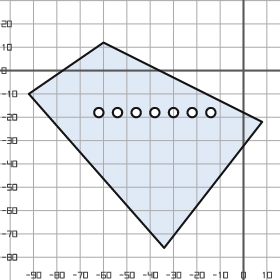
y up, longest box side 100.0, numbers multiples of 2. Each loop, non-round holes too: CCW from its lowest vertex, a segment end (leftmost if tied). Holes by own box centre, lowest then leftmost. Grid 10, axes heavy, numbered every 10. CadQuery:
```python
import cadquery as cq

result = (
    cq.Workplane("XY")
    .moveTo(-34.0, -76.0)
    .lineTo(8.0, -22.0)
    .lineTo(-60.0, 12.0)
    .lineTo(-92.0, -10.0)
    .close()
    .moveTo(-62.0, -18.0)
    .circle(2.0)
    .moveTo(-54.0, -18.0)
    .circle(2.0)
    .moveTo(-46.0, -18.0)
    .circle(2.0)
    .moveTo(-38.0, -18.0)
    .circle(2.0)
    .moveTo(-30.0, -18.0)
    .circle(2.0)
    .moveTo(-22.0, -18.0)
    .circle(2.0)
    .moveTo(-14.0, -18.0)
    .circle(2.0)
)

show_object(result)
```